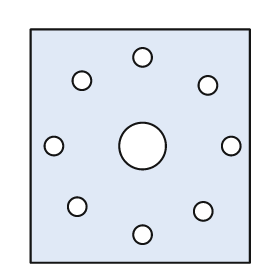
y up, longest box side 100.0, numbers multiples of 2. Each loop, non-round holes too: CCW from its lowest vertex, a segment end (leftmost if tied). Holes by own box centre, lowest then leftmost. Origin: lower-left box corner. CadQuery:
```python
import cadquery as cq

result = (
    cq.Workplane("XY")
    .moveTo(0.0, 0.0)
    .lineTo(94.0, 0.0)
    .lineTo(94.0, 100.0)
    .lineTo(0.0, 100.0)
    .close()
    .moveTo(48.0, 12.0)
    .circle(4.0)
    .moveTo(74.0, 22.0)
    .circle(4.0)
    .moveTo(20.0, 24.0)
    .circle(4.0)
    .moveTo(10.0, 50.0)
    .circle(4.0)
    .moveTo(48.0, 50.0)
    .circle(10.0)
    .moveTo(86.0, 50.0)
    .circle(4.0)
    .moveTo(76.0, 76.0)
    .circle(4.0)
    .moveTo(22.0, 78.0)
    .circle(4.0)
    .moveTo(48.0, 88.0)
    .circle(4.0)
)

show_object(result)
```